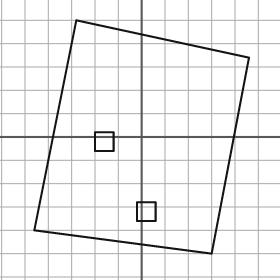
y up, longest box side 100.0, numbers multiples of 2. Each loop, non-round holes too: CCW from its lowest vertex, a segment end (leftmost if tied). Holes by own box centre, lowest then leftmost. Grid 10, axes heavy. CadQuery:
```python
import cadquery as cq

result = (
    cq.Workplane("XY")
    .moveTo(30.0, -50.0)
    .lineTo(46.0, 34.0)
    .lineTo(-28.0, 50.0)
    .lineTo(-46.0, -40.0)
    .close()
    .moveTo(-2.0, -36.0)
    .lineTo(6.0, -36.0)
    .lineTo(6.0, -28.0)
    .lineTo(-2.0, -28.0)
    .close()
    .moveTo(-20.0, -6.0)
    .lineTo(-12.0, -6.0)
    .lineTo(-12.0, 2.0)
    .lineTo(-20.0, 2.0)
    .close()
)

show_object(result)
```